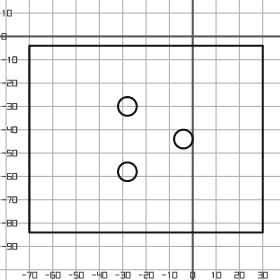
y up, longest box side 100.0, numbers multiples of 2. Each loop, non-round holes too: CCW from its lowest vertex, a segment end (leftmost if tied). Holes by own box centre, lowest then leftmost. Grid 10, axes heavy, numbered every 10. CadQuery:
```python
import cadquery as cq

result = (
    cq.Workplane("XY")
    .moveTo(-70.0, -84.0)
    .lineTo(30.0, -84.0)
    .lineTo(30.0, -4.0)
    .lineTo(-70.0, -4.0)
    .close()
    .moveTo(-28.0, -58.0)
    .circle(4.0)
    .moveTo(-4.0, -44.0)
    .circle(4.0)
    .moveTo(-28.0, -30.0)
    .circle(4.0)
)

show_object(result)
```